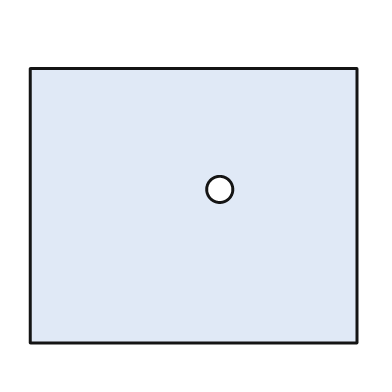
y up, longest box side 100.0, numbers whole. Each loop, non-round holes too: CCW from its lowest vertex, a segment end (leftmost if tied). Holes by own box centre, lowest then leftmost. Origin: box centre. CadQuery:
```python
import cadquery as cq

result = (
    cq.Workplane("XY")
    .moveTo(-50.0, -42.0)
    .lineTo(50.0, -42.0)
    .lineTo(50.0, 42.0)
    .lineTo(-50.0, 42.0)
    .close()
    .moveTo(8.0, 5.0)
    .circle(4.0)
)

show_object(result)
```